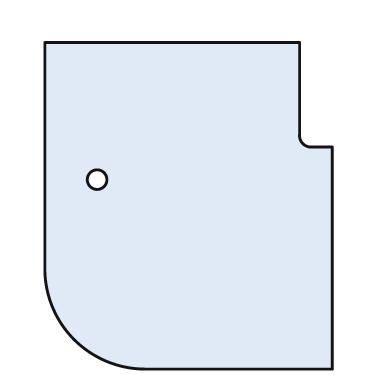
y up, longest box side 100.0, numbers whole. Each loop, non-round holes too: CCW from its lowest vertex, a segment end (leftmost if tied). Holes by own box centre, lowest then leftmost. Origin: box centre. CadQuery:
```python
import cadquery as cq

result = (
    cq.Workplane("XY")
    .moveTo(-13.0, -50.0)
    .lineTo(44.0, -50.0)
    .lineTo(44.0, 18.0)
    .lineTo(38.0, 18.0)
    .threePointArc((35.0, 19.0), (34.0, 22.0))
    .lineTo(34.0, 50.0)
    .lineTo(-44.0, 50.0)
    .lineTo(-44.0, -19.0)
    .threePointArc((-35.0, -41.0), (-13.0, -50.0))
    .close()
    .moveTo(-28.0, 8.0)
    .circle(3.0)
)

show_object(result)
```